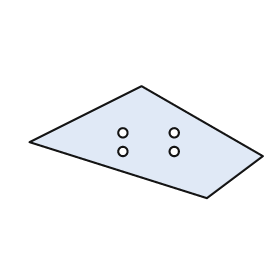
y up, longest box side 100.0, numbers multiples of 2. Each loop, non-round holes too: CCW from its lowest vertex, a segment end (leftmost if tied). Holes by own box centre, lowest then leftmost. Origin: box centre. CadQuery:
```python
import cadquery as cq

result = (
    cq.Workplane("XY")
    .moveTo(26.0, -24.0)
    .lineTo(50.0, -6.0)
    .lineTo(-2.0, 24.0)
    .lineTo(-50.0, 0.0)
    .close()
    .moveTo(-10.0, -4.0)
    .circle(2.0)
    .moveTo(12.0, -4.0)
    .circle(2.0)
    .moveTo(-10.0, 4.0)
    .circle(2.0)
    .moveTo(12.0, 4.0)
    .circle(2.0)
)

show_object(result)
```